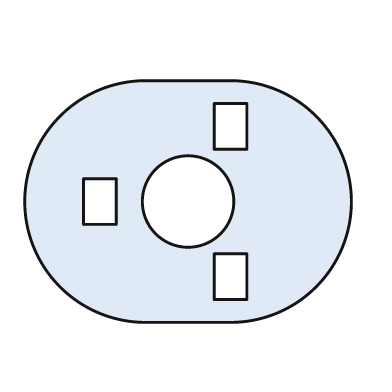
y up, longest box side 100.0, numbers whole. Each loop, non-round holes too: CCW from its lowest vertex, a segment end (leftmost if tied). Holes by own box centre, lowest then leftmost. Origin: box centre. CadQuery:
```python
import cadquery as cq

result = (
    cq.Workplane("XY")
    .moveTo(-13.0, -37.0)
    .lineTo(13.0, -37.0)
    .threePointArc((50.0, 0.0), (13.0, 37.0))
    .lineTo(-13.0, 37.0)
    .threePointArc((-50.0, 0.0), (-13.0, -37.0))
    .close()
    .moveTo(8.0, -30.0)
    .lineTo(18.0, -30.0)
    .lineTo(18.0, -16.0)
    .lineTo(8.0, -16.0)
    .close()
    .moveTo(-32.0, -7.0)
    .lineTo(-22.0, -7.0)
    .lineTo(-22.0, 7.0)
    .lineTo(-32.0, 7.0)
    .close()
    .moveTo(0.0, 0.0)
    .circle(14.0)
    .moveTo(8.0, 16.0)
    .lineTo(18.0, 16.0)
    .lineTo(18.0, 30.0)
    .lineTo(8.0, 30.0)
    .close()
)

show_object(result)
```